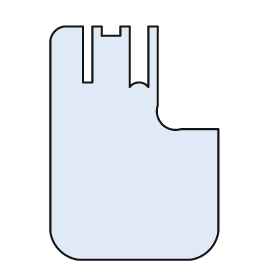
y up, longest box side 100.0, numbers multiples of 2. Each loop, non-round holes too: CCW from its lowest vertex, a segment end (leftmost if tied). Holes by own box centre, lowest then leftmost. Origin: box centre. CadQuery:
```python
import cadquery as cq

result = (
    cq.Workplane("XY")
    .moveTo(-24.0, -50.0)
    .lineTo(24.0, -50.0)
    .threePointArc((32.0, -46.0), (36.0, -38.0))
    .lineTo(36.0, 6.0)
    .lineTo(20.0, 6.0)
    .threePointArc((12.0, 8.0), (10.0, 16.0))
    .lineTo(10.0, 50.0)
    .lineTo(6.0, 50.0)
    .lineTo(6.0, 24.0)
    .threePointArc((2.0, 26.0), (-2.0, 24.0))
    .lineTo(-2.0, 50.0)
    .lineTo(-6.0, 50.0)
    .lineTo(-6.0, 46.0)
    .lineTo(-14.0, 46.0)
    .lineTo(-14.0, 50.0)
    .lineTo(-18.0, 50.0)
    .lineTo(-18.0, 26.0)
    .lineTo(-22.0, 26.0)
    .lineTo(-22.0, 50.0)
    .lineTo(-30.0, 50.0)
    .threePointArc((-34.0, 48.0), (-36.0, 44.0))
    .lineTo(-36.0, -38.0)
    .threePointArc((-32.0, -46.0), (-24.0, -50.0))
    .close()
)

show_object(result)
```